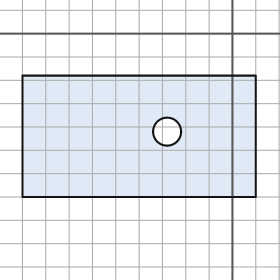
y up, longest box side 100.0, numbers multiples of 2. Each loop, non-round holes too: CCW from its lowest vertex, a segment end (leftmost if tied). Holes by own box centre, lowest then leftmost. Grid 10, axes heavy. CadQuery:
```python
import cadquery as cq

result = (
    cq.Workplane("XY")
    .moveTo(-90.0, -70.0)
    .lineTo(10.0, -70.0)
    .lineTo(10.0, -18.0)
    .lineTo(-90.0, -18.0)
    .close()
    .moveTo(-28.0, -42.0)
    .circle(6.0)
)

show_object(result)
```